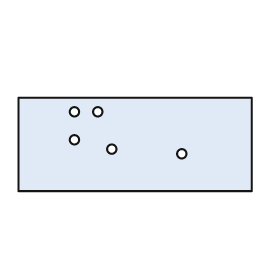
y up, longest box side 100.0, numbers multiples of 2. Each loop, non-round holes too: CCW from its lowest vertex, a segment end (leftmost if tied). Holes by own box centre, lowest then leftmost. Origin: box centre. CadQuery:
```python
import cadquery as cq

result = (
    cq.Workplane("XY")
    .moveTo(-50.0, -20.0)
    .lineTo(50.0, -20.0)
    .lineTo(50.0, 20.0)
    .lineTo(-50.0, 20.0)
    .close()
    .moveTo(20.0, -4.0)
    .circle(2.0)
    .moveTo(-10.0, -2.0)
    .circle(2.0)
    .moveTo(-26.0, 2.0)
    .circle(2.0)
    .moveTo(-26.0, 14.0)
    .circle(2.0)
    .moveTo(-16.0, 14.0)
    .circle(2.0)
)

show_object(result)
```